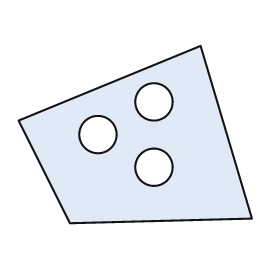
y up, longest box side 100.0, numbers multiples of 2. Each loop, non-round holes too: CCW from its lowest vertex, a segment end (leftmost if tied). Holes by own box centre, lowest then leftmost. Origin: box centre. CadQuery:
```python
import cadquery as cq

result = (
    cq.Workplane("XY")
    .moveTo(-28.0, -38.0)
    .lineTo(50.0, -36.0)
    .lineTo(28.0, 38.0)
    .lineTo(-50.0, 6.0)
    .close()
    .moveTo(8.0, -14.0)
    .circle(8.0)
    .moveTo(-16.0, 0.0)
    .circle(8.0)
    .moveTo(8.0, 14.0)
    .circle(8.0)
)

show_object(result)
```